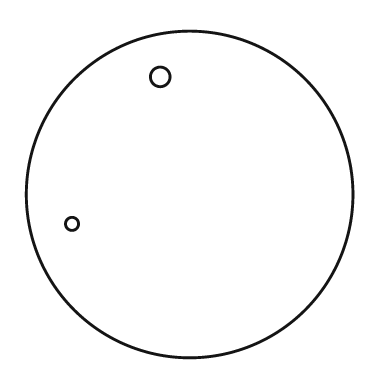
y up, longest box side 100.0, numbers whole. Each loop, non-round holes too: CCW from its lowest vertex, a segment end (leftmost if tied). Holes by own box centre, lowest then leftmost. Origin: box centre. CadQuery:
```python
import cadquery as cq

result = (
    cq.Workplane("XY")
    .moveTo(0.0, 0.0)
    .circle(50.0)
    .moveTo(-36.0, -9.0)
    .circle(2.0)
    .moveTo(-9.0, 36.0)
    .circle(3.0)
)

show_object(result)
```